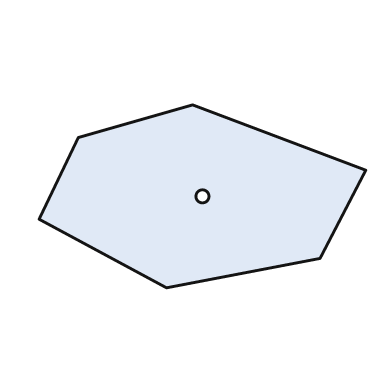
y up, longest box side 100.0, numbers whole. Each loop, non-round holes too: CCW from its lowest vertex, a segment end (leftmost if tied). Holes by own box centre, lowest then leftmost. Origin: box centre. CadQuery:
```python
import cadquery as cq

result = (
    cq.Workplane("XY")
    .moveTo(-11.0, -28.0)
    .lineTo(36.0, -19.0)
    .lineTo(50.0, 8.0)
    .lineTo(-3.0, 28.0)
    .lineTo(-38.0, 18.0)
    .lineTo(-50.0, -7.0)
    .close()
    .moveTo(0.0, 0.0)
    .circle(2.0)
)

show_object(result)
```